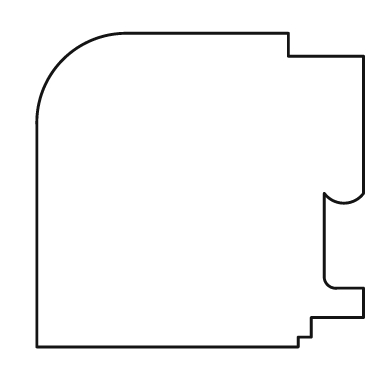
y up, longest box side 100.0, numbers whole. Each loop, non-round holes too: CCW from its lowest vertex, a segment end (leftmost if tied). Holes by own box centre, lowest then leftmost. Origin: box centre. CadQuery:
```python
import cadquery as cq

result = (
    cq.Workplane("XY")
    .moveTo(-50.0, -48.0)
    .lineTo(30.0, -48.0)
    .lineTo(30.0, -45.0)
    .lineTo(34.0, -45.0)
    .lineTo(34.0, -39.0)
    .lineTo(50.0, -39.0)
    .lineTo(50.0, -30.0)
    .lineTo(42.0, -30.0)
    .threePointArc((39.0, -29.0), (38.0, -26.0))
    .lineTo(38.0, -1.0)
    .threePointArc((44.0, -4.0), (50.0, -1.0))
    .lineTo(50.0, 41.0)
    .lineTo(27.0, 41.0)
    .lineTo(27.0, 48.0)
    .lineTo(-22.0, 48.0)
    .threePointArc((-42.0, 40.0), (-50.0, 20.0))
    .close()
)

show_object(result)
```